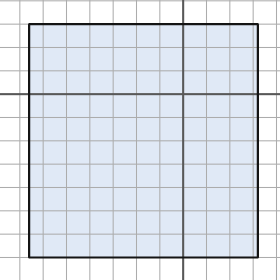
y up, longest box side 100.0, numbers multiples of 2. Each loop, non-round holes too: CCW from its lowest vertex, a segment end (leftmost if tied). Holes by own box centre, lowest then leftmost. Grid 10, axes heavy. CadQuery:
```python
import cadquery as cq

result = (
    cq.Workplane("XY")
    .moveTo(-66.0, -70.0)
    .lineTo(32.0, -70.0)
    .lineTo(32.0, 30.0)
    .lineTo(-66.0, 30.0)
    .close()
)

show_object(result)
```